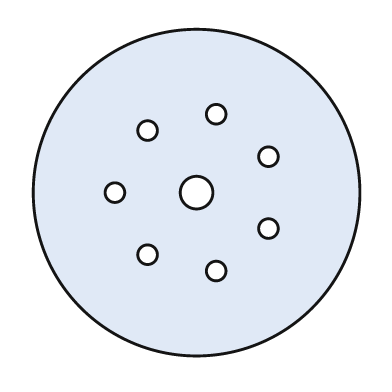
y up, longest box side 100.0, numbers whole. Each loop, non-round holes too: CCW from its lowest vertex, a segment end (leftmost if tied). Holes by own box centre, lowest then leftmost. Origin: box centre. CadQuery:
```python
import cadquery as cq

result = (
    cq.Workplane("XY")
    .moveTo(0.0, 0.0)
    .circle(50.0)
    .moveTo(6.0, -24.0)
    .circle(3.0)
    .moveTo(-15.0, -19.0)
    .circle(3.0)
    .moveTo(22.0, -11.0)
    .circle(3.0)
    .moveTo(-25.0, 0.0)
    .circle(3.0)
    .moveTo(0.0, 0.0)
    .circle(5.0)
    .moveTo(22.0, 11.0)
    .circle(3.0)
    .moveTo(-15.0, 19.0)
    .circle(3.0)
    .moveTo(6.0, 24.0)
    .circle(3.0)
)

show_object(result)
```